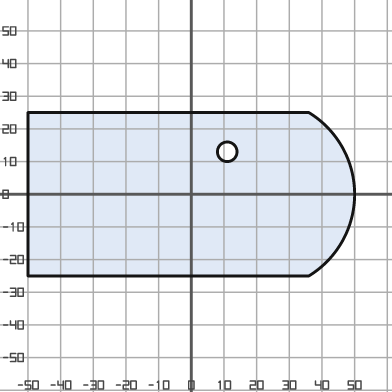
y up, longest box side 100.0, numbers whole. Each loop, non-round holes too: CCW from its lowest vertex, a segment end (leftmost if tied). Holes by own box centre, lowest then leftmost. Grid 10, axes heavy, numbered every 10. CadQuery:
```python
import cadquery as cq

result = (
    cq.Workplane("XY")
    .moveTo(-50.0, -25.0)
    .lineTo(36.0, -25.0)
    .threePointArc((50.0, 0.0), (36.0, 25.0))
    .lineTo(-50.0, 25.0)
    .close()
    .moveTo(11.0, 13.0)
    .circle(3.0)
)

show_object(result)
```